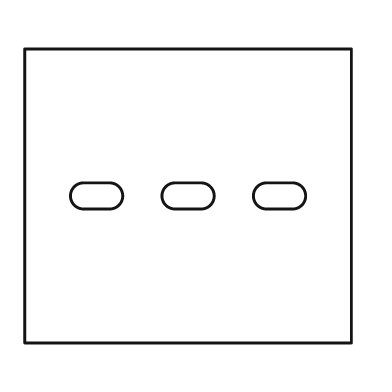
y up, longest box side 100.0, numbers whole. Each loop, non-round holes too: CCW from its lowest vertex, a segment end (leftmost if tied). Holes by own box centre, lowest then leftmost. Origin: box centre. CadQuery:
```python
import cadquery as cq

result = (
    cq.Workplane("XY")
    .moveTo(-50.0, -45.0)
    .lineTo(50.0, -45.0)
    .lineTo(50.0, 45.0)
    .lineTo(-50.0, 45.0)
    .close()
    .moveTo(-32.0, -4.0)
    .lineTo(-24.0, -4.0)
    .threePointArc((-20.0, 0.0), (-24.0, 4.0))
    .lineTo(-32.0, 4.0)
    .threePointArc((-36.0, 0.0), (-32.0, -4.0))
    .close()
    .moveTo(-4.0, -4.0)
    .lineTo(4.0, -4.0)
    .threePointArc((8.0, 0.0), (4.0, 4.0))
    .lineTo(-4.0, 4.0)
    .threePointArc((-8.0, 0.0), (-4.0, -4.0))
    .close()
    .moveTo(24.0, -4.0)
    .lineTo(32.0, -4.0)
    .threePointArc((36.0, 0.0), (32.0, 4.0))
    .lineTo(24.0, 4.0)
    .threePointArc((20.0, 0.0), (24.0, -4.0))
    .close()
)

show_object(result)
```